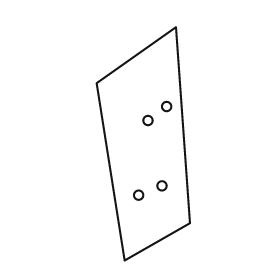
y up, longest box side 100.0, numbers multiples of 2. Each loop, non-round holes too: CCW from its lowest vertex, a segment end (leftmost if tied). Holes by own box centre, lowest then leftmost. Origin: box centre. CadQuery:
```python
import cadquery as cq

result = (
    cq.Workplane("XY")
    .moveTo(-8.0, -50.0)
    .lineTo(20.0, -34.0)
    .lineTo(14.0, 50.0)
    .lineTo(-20.0, 26.0)
    .close()
    .moveTo(-2.0, -22.0)
    .circle(2.0)
    .moveTo(8.0, -18.0)
    .circle(2.0)
    .moveTo(2.0, 10.0)
    .circle(2.0)
    .moveTo(10.0, 16.0)
    .circle(2.0)
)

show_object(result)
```